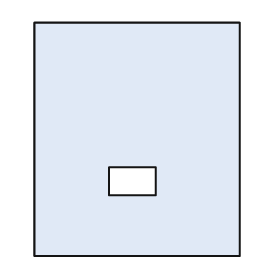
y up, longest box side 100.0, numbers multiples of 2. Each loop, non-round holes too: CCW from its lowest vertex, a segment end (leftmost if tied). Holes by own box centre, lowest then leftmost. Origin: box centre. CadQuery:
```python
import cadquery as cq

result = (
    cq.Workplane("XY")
    .moveTo(-44.0, -50.0)
    .lineTo(44.0, -50.0)
    .lineTo(44.0, 50.0)
    .lineTo(-44.0, 50.0)
    .close()
    .moveTo(-12.0, -24.0)
    .lineTo(8.0, -24.0)
    .lineTo(8.0, -12.0)
    .lineTo(-12.0, -12.0)
    .close()
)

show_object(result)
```